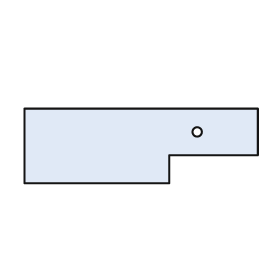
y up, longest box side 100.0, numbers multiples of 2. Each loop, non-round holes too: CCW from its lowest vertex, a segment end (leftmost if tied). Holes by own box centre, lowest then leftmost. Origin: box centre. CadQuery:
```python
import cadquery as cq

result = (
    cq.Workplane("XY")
    .moveTo(-50.0, -16.0)
    .lineTo(12.0, -16.0)
    .lineTo(12.0, -4.0)
    .lineTo(50.0, -4.0)
    .lineTo(50.0, 16.0)
    .lineTo(-50.0, 16.0)
    .close()
    .moveTo(24.0, 6.0)
    .circle(2.0)
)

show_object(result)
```